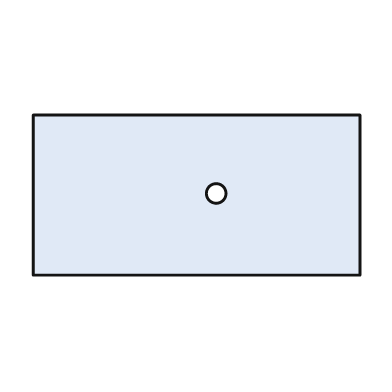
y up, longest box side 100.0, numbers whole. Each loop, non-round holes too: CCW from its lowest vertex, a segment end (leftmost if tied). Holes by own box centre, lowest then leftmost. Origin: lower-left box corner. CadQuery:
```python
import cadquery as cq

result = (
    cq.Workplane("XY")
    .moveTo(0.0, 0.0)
    .lineTo(100.0, 0.0)
    .lineTo(100.0, 49.0)
    .lineTo(0.0, 49.0)
    .close()
    .moveTo(56.0, 25.0)
    .circle(3.0)
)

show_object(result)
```